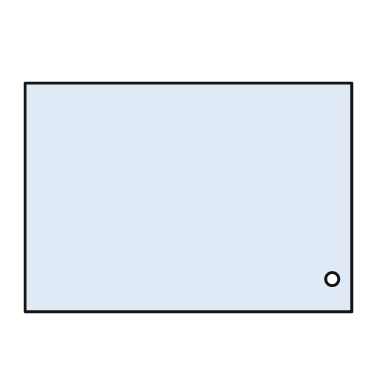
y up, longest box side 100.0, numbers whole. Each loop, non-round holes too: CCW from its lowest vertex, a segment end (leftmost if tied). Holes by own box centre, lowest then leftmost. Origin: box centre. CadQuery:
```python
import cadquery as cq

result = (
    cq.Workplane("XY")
    .moveTo(-50.0, -35.0)
    .lineTo(50.0, -35.0)
    .lineTo(50.0, 35.0)
    .lineTo(-50.0, 35.0)
    .close()
    .moveTo(44.0, -25.0)
    .circle(2.0)
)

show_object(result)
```